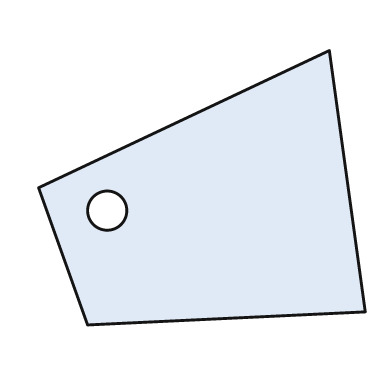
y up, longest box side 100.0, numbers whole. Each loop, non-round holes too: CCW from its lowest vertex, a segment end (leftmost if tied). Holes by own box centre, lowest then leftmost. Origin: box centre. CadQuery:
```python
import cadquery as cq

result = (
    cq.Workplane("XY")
    .moveTo(-35.0, -42.0)
    .lineTo(50.0, -38.0)
    .lineTo(39.0, 42.0)
    .lineTo(-50.0, 0.0)
    .close()
    .moveTo(-29.0, -7.0)
    .circle(6.0)
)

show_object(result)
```